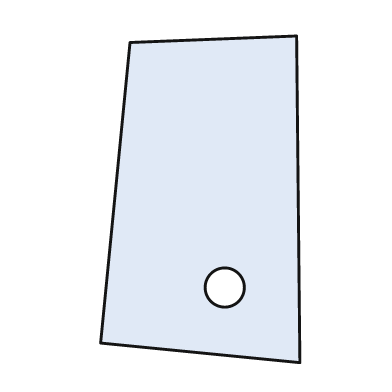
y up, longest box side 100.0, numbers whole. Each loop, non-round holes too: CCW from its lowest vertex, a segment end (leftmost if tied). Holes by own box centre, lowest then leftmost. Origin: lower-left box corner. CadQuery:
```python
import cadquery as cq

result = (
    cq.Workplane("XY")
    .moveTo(61.0, 0.0)
    .lineTo(60.0, 100.0)
    .lineTo(9.0, 98.0)
    .lineTo(0.0, 6.0)
    .close()
    .moveTo(38.0, 23.0)
    .circle(6.0)
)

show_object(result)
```